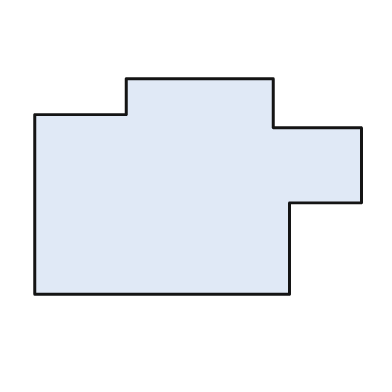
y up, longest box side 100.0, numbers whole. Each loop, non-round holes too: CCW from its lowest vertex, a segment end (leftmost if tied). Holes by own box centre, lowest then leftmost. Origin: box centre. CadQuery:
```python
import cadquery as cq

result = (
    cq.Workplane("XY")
    .moveTo(-50.0, -33.0)
    .lineTo(28.0, -33.0)
    .lineTo(28.0, -5.0)
    .lineTo(50.0, -5.0)
    .lineTo(50.0, 18.0)
    .lineTo(23.0, 18.0)
    .lineTo(23.0, 33.0)
    .lineTo(-22.0, 33.0)
    .lineTo(-22.0, 22.0)
    .lineTo(-50.0, 22.0)
    .close()
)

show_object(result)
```